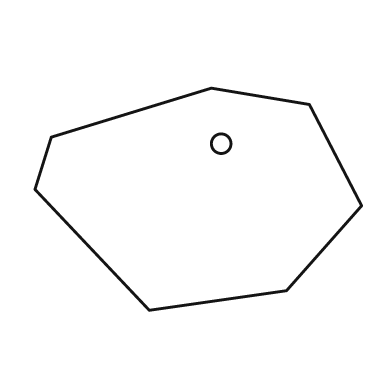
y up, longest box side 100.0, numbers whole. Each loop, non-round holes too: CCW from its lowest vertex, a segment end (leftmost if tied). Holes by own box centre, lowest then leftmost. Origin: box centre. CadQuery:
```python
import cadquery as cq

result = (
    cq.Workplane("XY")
    .moveTo(-15.0, -34.0)
    .lineTo(27.0, -28.0)
    .lineTo(50.0, -2.0)
    .lineTo(34.0, 29.0)
    .lineTo(4.0, 34.0)
    .lineTo(-45.0, 19.0)
    .lineTo(-50.0, 3.0)
    .close()
    .moveTo(7.0, 17.0)
    .circle(3.0)
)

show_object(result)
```